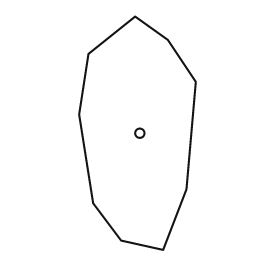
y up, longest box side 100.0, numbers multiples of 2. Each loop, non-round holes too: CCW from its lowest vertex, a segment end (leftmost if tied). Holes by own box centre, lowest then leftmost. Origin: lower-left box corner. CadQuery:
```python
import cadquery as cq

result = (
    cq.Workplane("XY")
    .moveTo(36.0, 0.0)
    .lineTo(46.0, 26.0)
    .lineTo(50.0, 72.0)
    .lineTo(38.0, 90.0)
    .lineTo(24.0, 100.0)
    .lineTo(4.0, 84.0)
    .lineTo(0.0, 58.0)
    .lineTo(6.0, 20.0)
    .lineTo(18.0, 4.0)
    .close()
    .moveTo(26.0, 50.0)
    .circle(2.0)
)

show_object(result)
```